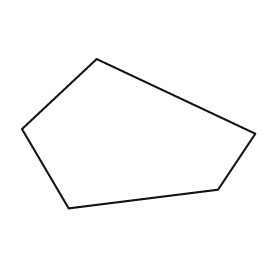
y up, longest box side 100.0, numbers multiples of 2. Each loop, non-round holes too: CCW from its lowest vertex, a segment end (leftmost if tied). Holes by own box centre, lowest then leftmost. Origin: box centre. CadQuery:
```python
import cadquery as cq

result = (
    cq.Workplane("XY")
    .moveTo(-30.0, -32.0)
    .lineTo(34.0, -24.0)
    .lineTo(50.0, 0.0)
    .lineTo(-18.0, 32.0)
    .lineTo(-50.0, 2.0)
    .close()
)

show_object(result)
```